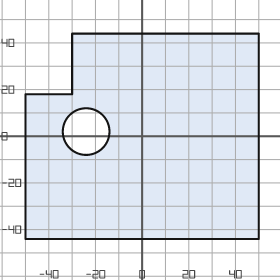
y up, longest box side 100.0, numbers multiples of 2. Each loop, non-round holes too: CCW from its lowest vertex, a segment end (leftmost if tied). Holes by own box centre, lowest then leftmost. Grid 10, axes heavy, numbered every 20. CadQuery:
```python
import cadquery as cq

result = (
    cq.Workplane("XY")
    .moveTo(-50.0, -44.0)
    .lineTo(50.0, -44.0)
    .lineTo(50.0, 44.0)
    .lineTo(-30.0, 44.0)
    .lineTo(-30.0, 18.0)
    .lineTo(-50.0, 18.0)
    .close()
    .moveTo(-24.0, 2.0)
    .circle(10.0)
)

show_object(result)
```